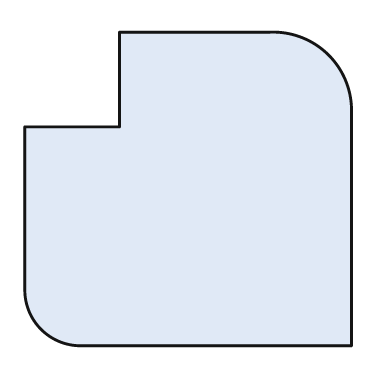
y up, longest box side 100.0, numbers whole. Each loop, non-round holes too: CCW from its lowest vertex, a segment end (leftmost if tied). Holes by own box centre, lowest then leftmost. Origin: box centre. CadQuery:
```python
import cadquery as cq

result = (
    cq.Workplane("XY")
    .moveTo(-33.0, -48.0)
    .lineTo(50.0, -48.0)
    .lineTo(50.0, 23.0)
    .threePointArc((43.0, 41.0), (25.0, 48.0))
    .lineTo(-21.0, 48.0)
    .lineTo(-21.0, 19.0)
    .lineTo(-50.0, 19.0)
    .lineTo(-50.0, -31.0)
    .threePointArc((-45.0, -43.0), (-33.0, -48.0))
    .close()
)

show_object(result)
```